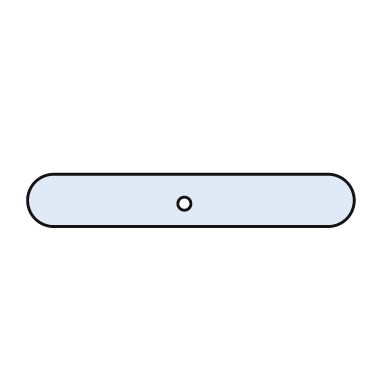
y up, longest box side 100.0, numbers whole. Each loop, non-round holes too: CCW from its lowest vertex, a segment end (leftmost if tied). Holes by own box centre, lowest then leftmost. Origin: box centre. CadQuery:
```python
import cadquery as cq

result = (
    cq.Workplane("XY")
    .moveTo(-42.0, -8.0)
    .lineTo(42.0, -8.0)
    .threePointArc((50.0, 0.0), (42.0, 8.0))
    .lineTo(-42.0, 8.0)
    .threePointArc((-50.0, 0.0), (-42.0, -8.0))
    .close()
    .moveTo(-2.0, -1.0)
    .circle(2.0)
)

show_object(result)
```